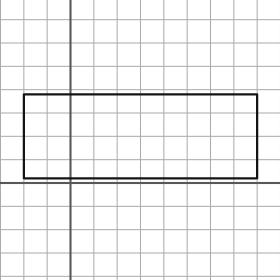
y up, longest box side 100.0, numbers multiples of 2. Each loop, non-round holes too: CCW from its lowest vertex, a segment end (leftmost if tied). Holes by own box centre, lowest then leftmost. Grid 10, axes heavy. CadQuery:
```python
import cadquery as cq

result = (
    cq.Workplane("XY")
    .moveTo(-20.0, 2.0)
    .lineTo(80.0, 2.0)
    .lineTo(80.0, 38.0)
    .lineTo(-20.0, 38.0)
    .close()
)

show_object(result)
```